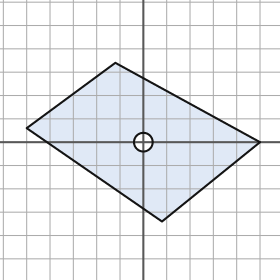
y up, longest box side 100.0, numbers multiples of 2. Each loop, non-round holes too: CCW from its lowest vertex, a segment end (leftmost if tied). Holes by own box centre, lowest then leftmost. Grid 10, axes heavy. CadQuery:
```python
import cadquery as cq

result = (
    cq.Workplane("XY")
    .moveTo(8.0, -34.0)
    .lineTo(50.0, 0.0)
    .lineTo(-12.0, 34.0)
    .lineTo(-50.0, 6.0)
    .close()
    .moveTo(0.0, 0.0)
    .circle(4.0)
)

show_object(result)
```